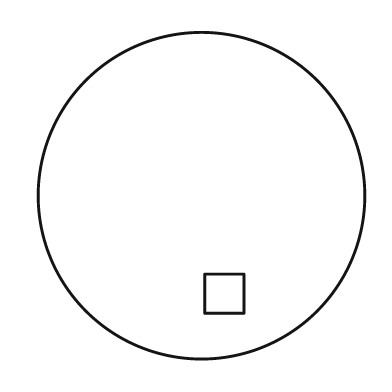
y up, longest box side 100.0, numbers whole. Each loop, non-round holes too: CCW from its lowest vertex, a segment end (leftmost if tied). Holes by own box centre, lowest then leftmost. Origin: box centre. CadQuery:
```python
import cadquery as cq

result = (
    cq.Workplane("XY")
    .moveTo(0.0, 0.0)
    .circle(50.0)
    .moveTo(1.0, -36.0)
    .lineTo(13.0, -36.0)
    .lineTo(13.0, -24.0)
    .lineTo(1.0, -24.0)
    .close()
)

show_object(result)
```